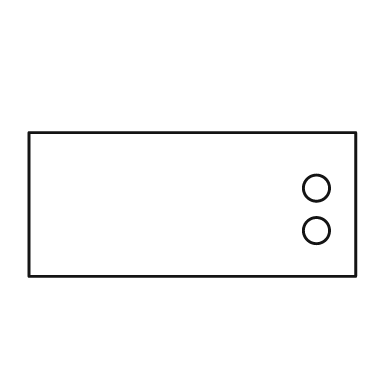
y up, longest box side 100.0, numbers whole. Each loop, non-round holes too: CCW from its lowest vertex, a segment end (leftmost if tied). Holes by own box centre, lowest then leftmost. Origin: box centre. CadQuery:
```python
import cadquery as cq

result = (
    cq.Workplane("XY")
    .moveTo(-50.0, -22.0)
    .lineTo(50.0, -22.0)
    .lineTo(50.0, 22.0)
    .lineTo(-50.0, 22.0)
    .close()
    .moveTo(38.0, -8.0)
    .circle(4.0)
    .moveTo(38.0, 5.0)
    .circle(4.0)
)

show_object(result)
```